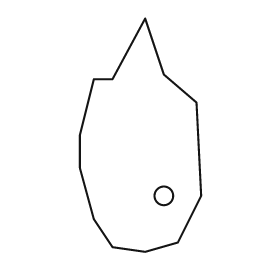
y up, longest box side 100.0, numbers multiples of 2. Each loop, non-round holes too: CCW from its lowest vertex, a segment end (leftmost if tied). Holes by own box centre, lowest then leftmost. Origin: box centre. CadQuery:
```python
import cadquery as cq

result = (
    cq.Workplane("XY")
    .moveTo(2.0, -50.0)
    .lineTo(16.0, -46.0)
    .lineTo(26.0, -26.0)
    .lineTo(24.0, 14.0)
    .lineTo(10.0, 26.0)
    .lineTo(2.0, 50.0)
    .lineTo(-12.0, 24.0)
    .lineTo(-20.0, 24.0)
    .lineTo(-26.0, 0.0)
    .lineTo(-26.0, -14.0)
    .lineTo(-20.0, -36.0)
    .lineTo(-12.0, -48.0)
    .close()
    .moveTo(10.0, -26.0)
    .circle(4.0)
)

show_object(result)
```